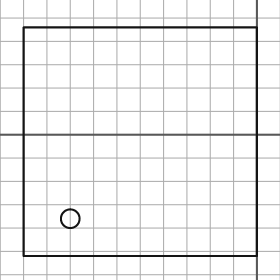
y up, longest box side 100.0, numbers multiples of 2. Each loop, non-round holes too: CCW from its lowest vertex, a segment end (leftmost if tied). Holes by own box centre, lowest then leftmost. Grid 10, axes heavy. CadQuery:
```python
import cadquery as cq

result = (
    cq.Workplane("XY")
    .moveTo(-100.0, -52.0)
    .lineTo(0.0, -52.0)
    .lineTo(0.0, 46.0)
    .lineTo(-100.0, 46.0)
    .close()
    .moveTo(-80.0, -36.0)
    .circle(4.0)
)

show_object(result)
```